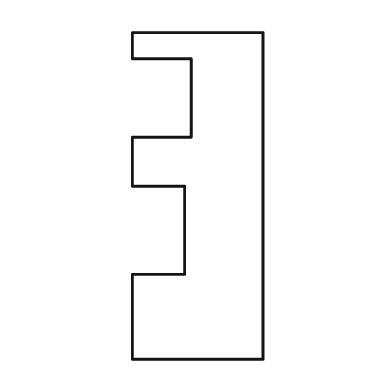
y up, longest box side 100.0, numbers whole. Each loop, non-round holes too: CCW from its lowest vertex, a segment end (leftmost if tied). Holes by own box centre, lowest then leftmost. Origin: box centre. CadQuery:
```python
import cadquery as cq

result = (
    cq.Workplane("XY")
    .moveTo(-20.0, -50.0)
    .lineTo(20.0, -50.0)
    .lineTo(20.0, 50.0)
    .lineTo(-20.0, 50.0)
    .lineTo(-20.0, 42.0)
    .lineTo(-2.0, 42.0)
    .lineTo(-2.0, 18.0)
    .lineTo(-20.0, 18.0)
    .lineTo(-20.0, 3.0)
    .lineTo(-4.0, 3.0)
    .lineTo(-4.0, -24.0)
    .lineTo(-20.0, -24.0)
    .close()
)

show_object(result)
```